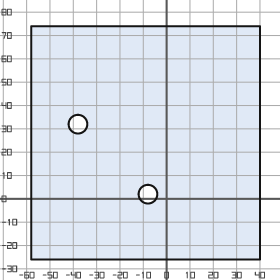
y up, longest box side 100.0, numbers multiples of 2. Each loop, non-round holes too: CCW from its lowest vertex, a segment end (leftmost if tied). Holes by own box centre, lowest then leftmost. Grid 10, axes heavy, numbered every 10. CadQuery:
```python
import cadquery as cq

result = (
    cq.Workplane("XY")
    .moveTo(-58.0, -26.0)
    .lineTo(40.0, -26.0)
    .lineTo(40.0, 74.0)
    .lineTo(-58.0, 74.0)
    .close()
    .moveTo(-8.0, 2.0)
    .circle(4.0)
    .moveTo(-38.0, 32.0)
    .circle(4.0)
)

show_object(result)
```